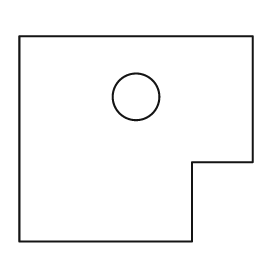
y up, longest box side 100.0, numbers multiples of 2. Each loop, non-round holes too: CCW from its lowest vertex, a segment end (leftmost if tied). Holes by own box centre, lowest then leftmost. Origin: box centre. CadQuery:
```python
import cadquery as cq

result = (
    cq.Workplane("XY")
    .moveTo(-50.0, -44.0)
    .lineTo(24.0, -44.0)
    .lineTo(24.0, -10.0)
    .lineTo(50.0, -10.0)
    .lineTo(50.0, 44.0)
    .lineTo(-50.0, 44.0)
    .close()
    .moveTo(0.0, 18.0)
    .circle(10.0)
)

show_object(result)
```